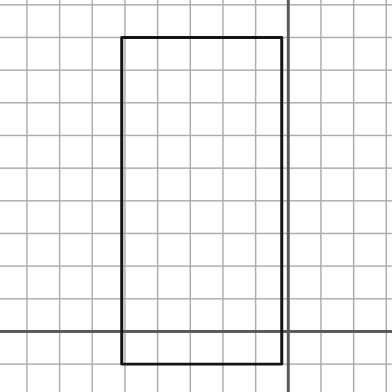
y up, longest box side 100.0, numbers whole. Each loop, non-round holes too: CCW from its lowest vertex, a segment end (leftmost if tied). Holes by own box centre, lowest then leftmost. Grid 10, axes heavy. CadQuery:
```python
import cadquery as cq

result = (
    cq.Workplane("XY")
    .moveTo(-51.0, -10.0)
    .lineTo(-2.0, -10.0)
    .lineTo(-2.0, 90.0)
    .lineTo(-51.0, 90.0)
    .close()
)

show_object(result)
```